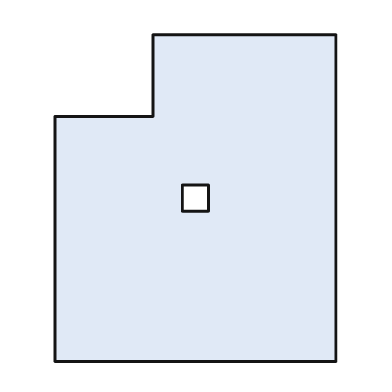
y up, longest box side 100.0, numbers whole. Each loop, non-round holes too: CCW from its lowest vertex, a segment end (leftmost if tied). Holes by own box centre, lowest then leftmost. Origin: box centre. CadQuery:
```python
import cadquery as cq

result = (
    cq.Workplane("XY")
    .moveTo(-43.0, -50.0)
    .lineTo(43.0, -50.0)
    .lineTo(43.0, 50.0)
    .lineTo(-13.0, 50.0)
    .lineTo(-13.0, 25.0)
    .lineTo(-43.0, 25.0)
    .close()
    .moveTo(-4.0, -4.0)
    .lineTo(4.0, -4.0)
    .lineTo(4.0, 4.0)
    .lineTo(-4.0, 4.0)
    .close()
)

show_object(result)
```